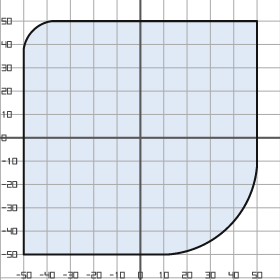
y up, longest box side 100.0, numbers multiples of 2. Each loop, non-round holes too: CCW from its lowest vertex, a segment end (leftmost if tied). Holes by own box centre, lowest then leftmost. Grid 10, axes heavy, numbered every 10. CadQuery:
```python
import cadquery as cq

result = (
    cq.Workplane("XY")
    .moveTo(-50.0, -50.0)
    .lineTo(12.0, -50.0)
    .threePointArc((38.0, -38.0), (50.0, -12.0))
    .lineTo(50.0, 50.0)
    .lineTo(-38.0, 50.0)
    .threePointArc((-46.0, 46.0), (-50.0, 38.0))
    .close()
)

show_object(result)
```